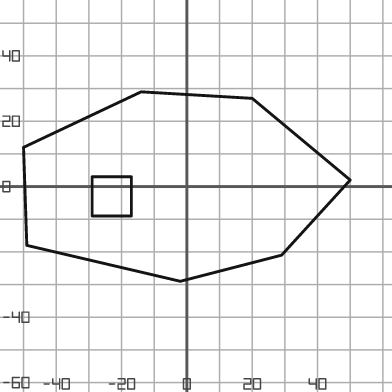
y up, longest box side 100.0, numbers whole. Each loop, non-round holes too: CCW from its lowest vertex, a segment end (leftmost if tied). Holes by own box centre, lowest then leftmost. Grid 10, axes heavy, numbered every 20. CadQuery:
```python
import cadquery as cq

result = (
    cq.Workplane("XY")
    .moveTo(-2.0, -29.0)
    .lineTo(29.0, -21.0)
    .lineTo(50.0, 2.0)
    .lineTo(20.0, 27.0)
    .lineTo(-14.0, 29.0)
    .lineTo(-50.0, 12.0)
    .lineTo(-49.0, -18.0)
    .close()
    .moveTo(-29.0, -9.0)
    .lineTo(-17.0, -9.0)
    .lineTo(-17.0, 3.0)
    .lineTo(-29.0, 3.0)
    .close()
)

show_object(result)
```